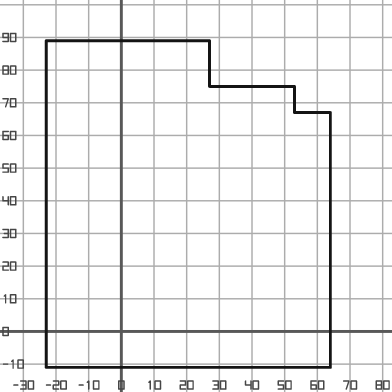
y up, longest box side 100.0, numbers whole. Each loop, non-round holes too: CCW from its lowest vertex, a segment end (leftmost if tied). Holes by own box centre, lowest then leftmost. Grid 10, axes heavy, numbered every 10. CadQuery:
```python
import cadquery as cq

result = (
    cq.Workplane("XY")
    .moveTo(-23.0, -11.0)
    .lineTo(64.0, -11.0)
    .lineTo(64.0, 67.0)
    .lineTo(53.0, 67.0)
    .lineTo(53.0, 75.0)
    .lineTo(27.0, 75.0)
    .lineTo(27.0, 89.0)
    .lineTo(-23.0, 89.0)
    .close()
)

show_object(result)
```